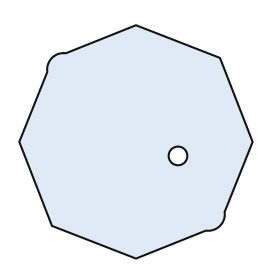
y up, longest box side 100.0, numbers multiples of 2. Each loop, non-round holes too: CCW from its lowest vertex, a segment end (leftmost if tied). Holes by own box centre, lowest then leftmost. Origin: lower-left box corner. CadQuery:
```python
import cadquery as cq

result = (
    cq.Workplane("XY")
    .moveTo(50.0, 0.0)
    .lineTo(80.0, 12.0)
    .threePointArc((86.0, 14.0), (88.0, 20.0))
    .lineTo(100.0, 50.0)
    .lineTo(86.0, 86.0)
    .lineTo(50.0, 100.0)
    .lineTo(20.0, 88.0)
    .threePointArc((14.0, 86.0), (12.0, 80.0))
    .lineTo(0.0, 50.0)
    .lineTo(14.0, 14.0)
    .close()
    .moveTo(68.0, 44.0)
    .circle(4.0)
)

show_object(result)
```